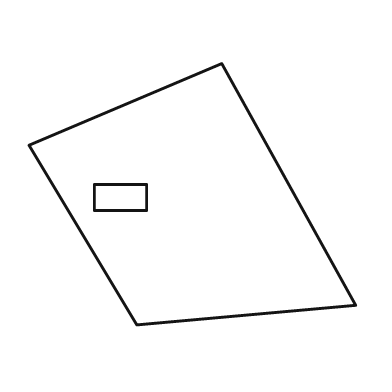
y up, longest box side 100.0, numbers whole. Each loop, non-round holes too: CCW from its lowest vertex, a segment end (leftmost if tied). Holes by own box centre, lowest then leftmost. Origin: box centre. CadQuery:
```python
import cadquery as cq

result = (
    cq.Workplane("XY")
    .moveTo(-17.0, -40.0)
    .lineTo(50.0, -34.0)
    .lineTo(9.0, 40.0)
    .lineTo(-50.0, 15.0)
    .close()
    .moveTo(-30.0, -5.0)
    .lineTo(-14.0, -5.0)
    .lineTo(-14.0, 3.0)
    .lineTo(-30.0, 3.0)
    .close()
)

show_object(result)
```